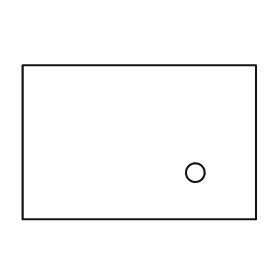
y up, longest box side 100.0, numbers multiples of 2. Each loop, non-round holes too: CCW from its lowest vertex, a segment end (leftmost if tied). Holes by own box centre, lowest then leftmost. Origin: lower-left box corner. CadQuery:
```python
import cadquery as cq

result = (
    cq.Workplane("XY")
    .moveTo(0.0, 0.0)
    .lineTo(100.0, 0.0)
    .lineTo(100.0, 66.0)
    .lineTo(0.0, 66.0)
    .close()
    .moveTo(74.0, 20.0)
    .circle(4.0)
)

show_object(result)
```